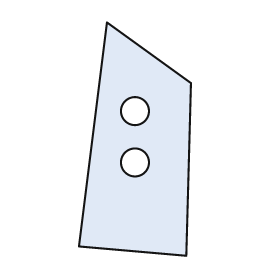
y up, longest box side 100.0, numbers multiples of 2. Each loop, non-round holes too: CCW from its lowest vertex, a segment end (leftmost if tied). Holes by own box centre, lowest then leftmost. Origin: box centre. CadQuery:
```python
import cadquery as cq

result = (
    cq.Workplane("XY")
    .moveTo(22.0, -50.0)
    .lineTo(24.0, 24.0)
    .lineTo(-12.0, 50.0)
    .lineTo(-24.0, -46.0)
    .close()
    .moveTo(0.0, -10.0)
    .circle(6.0)
    .moveTo(0.0, 12.0)
    .circle(6.0)
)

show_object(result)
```